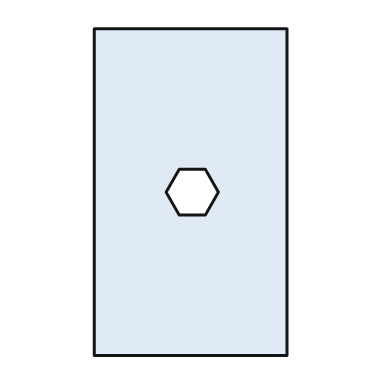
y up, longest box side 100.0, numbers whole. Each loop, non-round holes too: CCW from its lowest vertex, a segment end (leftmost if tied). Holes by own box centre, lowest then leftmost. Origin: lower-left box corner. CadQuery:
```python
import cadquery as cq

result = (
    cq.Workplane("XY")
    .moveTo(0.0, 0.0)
    .lineTo(59.0, 0.0)
    .lineTo(59.0, 100.0)
    .lineTo(0.0, 100.0)
    .close()
    .moveTo(26.0, 43.0)
    .lineTo(34.0, 43.0)
    .lineTo(38.0, 50.0)
    .lineTo(34.0, 57.0)
    .lineTo(26.0, 57.0)
    .lineTo(22.0, 50.0)
    .close()
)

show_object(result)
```